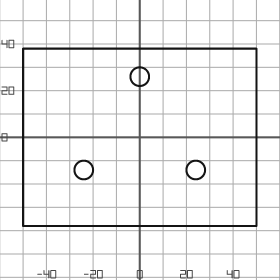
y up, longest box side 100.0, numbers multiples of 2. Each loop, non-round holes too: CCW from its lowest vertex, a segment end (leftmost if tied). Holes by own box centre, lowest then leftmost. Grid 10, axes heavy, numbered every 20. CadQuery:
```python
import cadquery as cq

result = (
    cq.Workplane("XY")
    .moveTo(-50.0, -38.0)
    .lineTo(50.0, -38.0)
    .lineTo(50.0, 38.0)
    .lineTo(-50.0, 38.0)
    .close()
    .moveTo(-24.0, -14.0)
    .circle(4.0)
    .moveTo(24.0, -14.0)
    .circle(4.0)
    .moveTo(0.0, 26.0)
    .circle(4.0)
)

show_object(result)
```